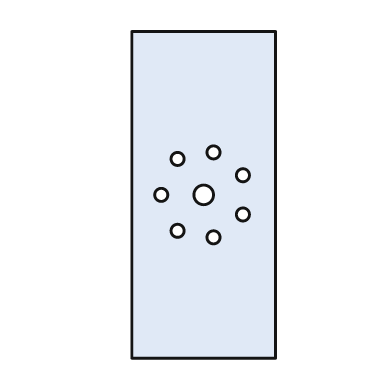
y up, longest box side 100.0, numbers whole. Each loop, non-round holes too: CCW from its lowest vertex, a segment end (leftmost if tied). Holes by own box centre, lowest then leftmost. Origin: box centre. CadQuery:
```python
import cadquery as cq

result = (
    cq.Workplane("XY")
    .moveTo(-22.0, -50.0)
    .lineTo(22.0, -50.0)
    .lineTo(22.0, 50.0)
    .lineTo(-22.0, 50.0)
    .close()
    .moveTo(3.0, -13.0)
    .circle(2.0)
    .moveTo(-8.0, -11.0)
    .circle(2.0)
    .moveTo(12.0, -6.0)
    .circle(2.0)
    .moveTo(-13.0, 0.0)
    .circle(2.0)
    .moveTo(0.0, 0.0)
    .circle(3.0)
    .moveTo(12.0, 6.0)
    .circle(2.0)
    .moveTo(-8.0, 11.0)
    .circle(2.0)
    .moveTo(3.0, 13.0)
    .circle(2.0)
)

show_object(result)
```